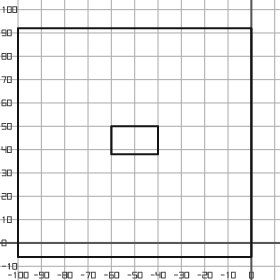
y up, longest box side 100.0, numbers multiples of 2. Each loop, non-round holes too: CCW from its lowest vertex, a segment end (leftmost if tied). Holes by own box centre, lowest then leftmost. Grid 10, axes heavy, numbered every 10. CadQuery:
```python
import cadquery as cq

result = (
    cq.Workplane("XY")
    .moveTo(-100.0, -6.0)
    .lineTo(0.0, -6.0)
    .lineTo(0.0, 92.0)
    .lineTo(-100.0, 92.0)
    .close()
    .moveTo(-60.0, 38.0)
    .lineTo(-40.0, 38.0)
    .lineTo(-40.0, 50.0)
    .lineTo(-60.0, 50.0)
    .close()
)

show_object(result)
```